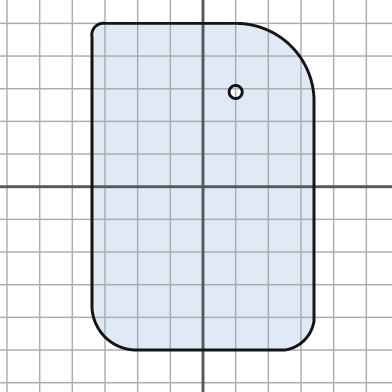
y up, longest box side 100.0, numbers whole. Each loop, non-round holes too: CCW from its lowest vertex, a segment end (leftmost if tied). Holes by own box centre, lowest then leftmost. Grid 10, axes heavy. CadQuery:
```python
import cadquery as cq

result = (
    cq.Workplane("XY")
    .moveTo(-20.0, -50.0)
    .lineTo(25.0, -50.0)
    .threePointArc((31.0, -47.0), (34.0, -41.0))
    .lineTo(34.0, 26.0)
    .threePointArc((27.0, 43.0), (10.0, 50.0))
    .lineTo(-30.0, 50.0)
    .threePointArc((-33.0, 49.0), (-34.0, 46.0))
    .lineTo(-34.0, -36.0)
    .threePointArc((-30.0, -46.0), (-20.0, -50.0))
    .close()
    .moveTo(10.0, 29.0)
    .circle(2.0)
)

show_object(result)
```